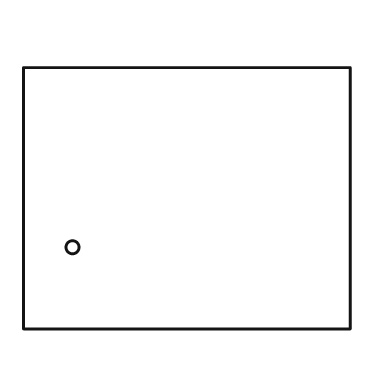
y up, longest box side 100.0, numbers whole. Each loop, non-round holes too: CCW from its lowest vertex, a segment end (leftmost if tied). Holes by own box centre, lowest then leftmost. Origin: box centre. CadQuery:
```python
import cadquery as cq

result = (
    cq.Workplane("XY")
    .moveTo(-50.0, -40.0)
    .lineTo(50.0, -40.0)
    .lineTo(50.0, 40.0)
    .lineTo(-50.0, 40.0)
    .close()
    .moveTo(-35.0, -15.0)
    .circle(2.0)
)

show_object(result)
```